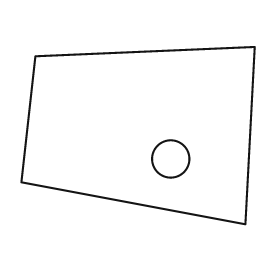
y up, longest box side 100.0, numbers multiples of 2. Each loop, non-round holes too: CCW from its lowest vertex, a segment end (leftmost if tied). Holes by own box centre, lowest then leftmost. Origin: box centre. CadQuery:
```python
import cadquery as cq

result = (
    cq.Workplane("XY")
    .moveTo(46.0, -38.0)
    .lineTo(50.0, 38.0)
    .lineTo(-44.0, 34.0)
    .lineTo(-50.0, -20.0)
    .close()
    .moveTo(14.0, -10.0)
    .circle(8.0)
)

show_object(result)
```